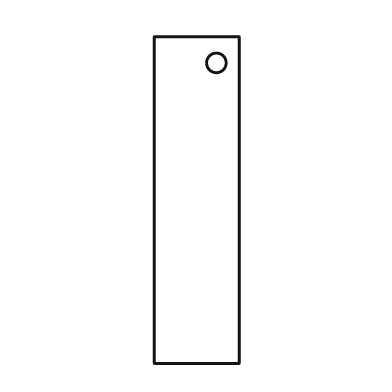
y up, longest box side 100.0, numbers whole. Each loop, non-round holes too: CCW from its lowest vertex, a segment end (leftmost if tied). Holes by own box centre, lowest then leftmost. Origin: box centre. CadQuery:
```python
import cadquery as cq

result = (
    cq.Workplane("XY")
    .moveTo(-13.0, -50.0)
    .lineTo(13.0, -50.0)
    .lineTo(13.0, 50.0)
    .lineTo(-13.0, 50.0)
    .close()
    .moveTo(6.0, 42.0)
    .circle(3.0)
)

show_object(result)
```